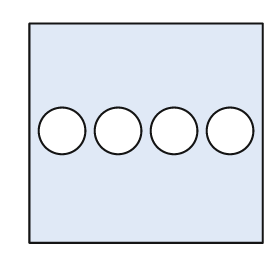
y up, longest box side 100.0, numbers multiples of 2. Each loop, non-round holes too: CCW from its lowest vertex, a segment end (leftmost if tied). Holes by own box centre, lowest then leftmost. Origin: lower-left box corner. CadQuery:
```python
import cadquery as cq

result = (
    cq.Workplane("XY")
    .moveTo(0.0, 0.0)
    .lineTo(100.0, 0.0)
    .lineTo(100.0, 94.0)
    .lineTo(0.0, 94.0)
    .close()
    .moveTo(14.0, 48.0)
    .circle(10.0)
    .moveTo(38.0, 48.0)
    .circle(10.0)
    .moveTo(62.0, 48.0)
    .circle(10.0)
    .moveTo(86.0, 48.0)
    .circle(10.0)
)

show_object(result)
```